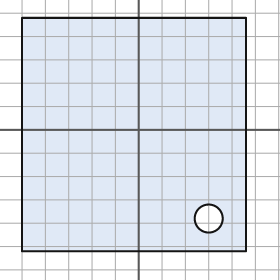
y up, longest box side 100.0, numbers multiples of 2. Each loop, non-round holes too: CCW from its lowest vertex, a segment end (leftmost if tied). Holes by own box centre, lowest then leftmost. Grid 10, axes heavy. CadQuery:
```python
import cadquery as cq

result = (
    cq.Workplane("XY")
    .moveTo(-50.0, -52.0)
    .lineTo(46.0, -52.0)
    .lineTo(46.0, 48.0)
    .lineTo(-50.0, 48.0)
    .close()
    .moveTo(30.0, -38.0)
    .circle(6.0)
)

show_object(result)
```